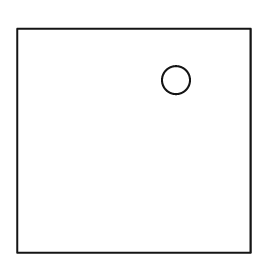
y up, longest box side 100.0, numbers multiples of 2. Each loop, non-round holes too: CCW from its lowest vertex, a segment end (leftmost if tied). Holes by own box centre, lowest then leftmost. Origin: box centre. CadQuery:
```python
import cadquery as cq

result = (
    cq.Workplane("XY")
    .moveTo(-50.0, -48.0)
    .lineTo(50.0, -48.0)
    .lineTo(50.0, 48.0)
    .lineTo(-50.0, 48.0)
    .close()
    .moveTo(18.0, 26.0)
    .circle(6.0)
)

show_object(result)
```